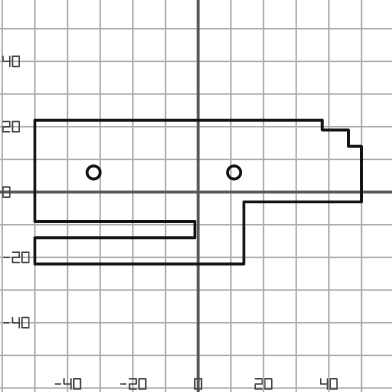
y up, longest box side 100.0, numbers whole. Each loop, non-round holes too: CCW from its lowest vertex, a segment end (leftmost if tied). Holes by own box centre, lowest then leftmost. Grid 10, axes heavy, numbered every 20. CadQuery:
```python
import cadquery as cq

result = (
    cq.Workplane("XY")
    .moveTo(-50.0, -22.0)
    .lineTo(14.0, -22.0)
    .lineTo(14.0, -3.0)
    .lineTo(50.0, -3.0)
    .lineTo(50.0, 14.0)
    .lineTo(46.0, 14.0)
    .lineTo(46.0, 19.0)
    .lineTo(38.0, 19.0)
    .lineTo(38.0, 22.0)
    .lineTo(-50.0, 22.0)
    .lineTo(-50.0, -9.0)
    .lineTo(-1.0, -9.0)
    .lineTo(-1.0, -14.0)
    .lineTo(-50.0, -14.0)
    .close()
    .moveTo(-32.0, 6.0)
    .circle(2.0)
    .moveTo(11.0, 6.0)
    .circle(2.0)
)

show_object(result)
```